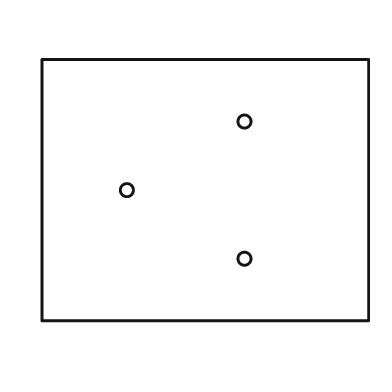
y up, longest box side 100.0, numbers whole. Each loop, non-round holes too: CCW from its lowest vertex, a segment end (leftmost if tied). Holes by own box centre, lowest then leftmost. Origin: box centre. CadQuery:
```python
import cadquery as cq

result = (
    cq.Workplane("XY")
    .moveTo(-50.0, -40.0)
    .lineTo(50.0, -40.0)
    .lineTo(50.0, 40.0)
    .lineTo(-50.0, 40.0)
    .close()
    .moveTo(12.0, -21.0)
    .circle(2.0)
    .moveTo(-24.0, 0.0)
    .circle(2.0)
    .moveTo(12.0, 21.0)
    .circle(2.0)
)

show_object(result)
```